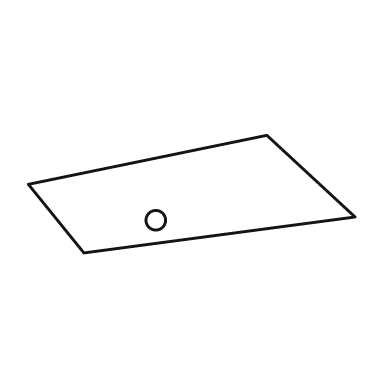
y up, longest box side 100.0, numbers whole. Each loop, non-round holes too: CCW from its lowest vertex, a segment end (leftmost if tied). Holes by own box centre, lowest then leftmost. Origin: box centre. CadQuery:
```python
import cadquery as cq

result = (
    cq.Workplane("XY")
    .moveTo(-33.0, -18.0)
    .lineTo(50.0, -7.0)
    .lineTo(23.0, 18.0)
    .lineTo(-50.0, 3.0)
    .close()
    .moveTo(-11.0, -8.0)
    .circle(3.0)
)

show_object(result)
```